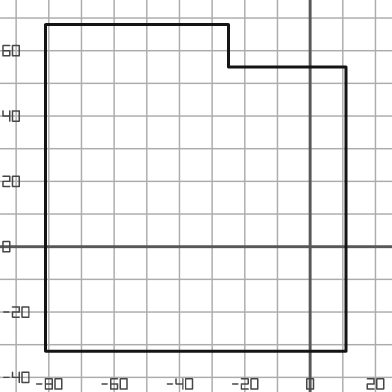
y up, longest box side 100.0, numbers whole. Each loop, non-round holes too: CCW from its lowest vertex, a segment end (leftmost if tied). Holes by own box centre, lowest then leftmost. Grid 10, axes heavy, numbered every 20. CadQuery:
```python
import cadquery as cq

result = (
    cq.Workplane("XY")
    .moveTo(-81.0, -32.0)
    .lineTo(11.0, -32.0)
    .lineTo(11.0, 55.0)
    .lineTo(-25.0, 55.0)
    .lineTo(-25.0, 68.0)
    .lineTo(-81.0, 68.0)
    .close()
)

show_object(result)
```